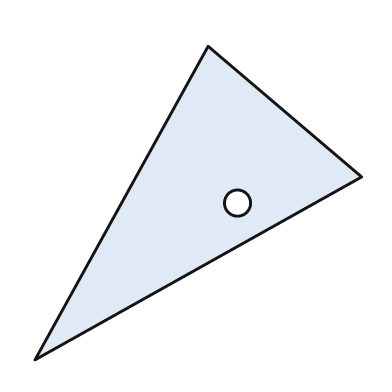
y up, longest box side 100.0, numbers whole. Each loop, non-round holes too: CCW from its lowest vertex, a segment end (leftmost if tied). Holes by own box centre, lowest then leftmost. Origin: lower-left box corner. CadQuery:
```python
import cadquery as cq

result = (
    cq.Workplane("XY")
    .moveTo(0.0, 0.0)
    .lineTo(100.0, 56.0)
    .lineTo(53.0, 96.0)
    .close()
    .moveTo(62.0, 48.0)
    .circle(4.0)
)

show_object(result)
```